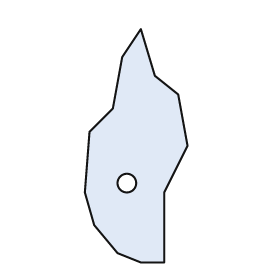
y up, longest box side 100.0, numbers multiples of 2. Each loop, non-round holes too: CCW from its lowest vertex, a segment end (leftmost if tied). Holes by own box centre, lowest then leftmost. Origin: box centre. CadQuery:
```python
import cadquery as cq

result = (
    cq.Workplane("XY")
    .moveTo(2.0, -50.0)
    .lineTo(12.0, -50.0)
    .lineTo(12.0, -20.0)
    .lineTo(22.0, 0.0)
    .lineTo(18.0, 22.0)
    .lineTo(8.0, 30.0)
    .lineTo(2.0, 50.0)
    .lineTo(-6.0, 38.0)
    .lineTo(-10.0, 16.0)
    .lineTo(-20.0, 6.0)
    .lineTo(-22.0, -20.0)
    .lineTo(-18.0, -34.0)
    .lineTo(-8.0, -46.0)
    .close()
    .moveTo(-4.0, -16.0)
    .circle(4.0)
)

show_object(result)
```